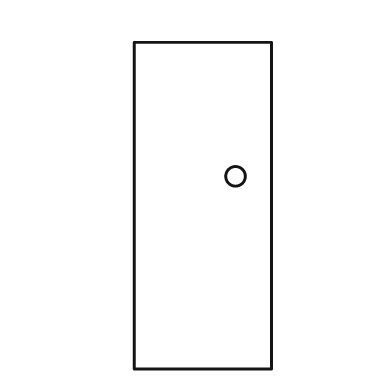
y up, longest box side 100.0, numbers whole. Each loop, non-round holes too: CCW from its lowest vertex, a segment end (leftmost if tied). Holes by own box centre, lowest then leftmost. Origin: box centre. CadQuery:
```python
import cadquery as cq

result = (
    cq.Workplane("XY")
    .moveTo(-21.0, -50.0)
    .lineTo(21.0, -50.0)
    .lineTo(21.0, 50.0)
    .lineTo(-21.0, 50.0)
    .close()
    .moveTo(10.0, 9.0)
    .circle(3.0)
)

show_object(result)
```